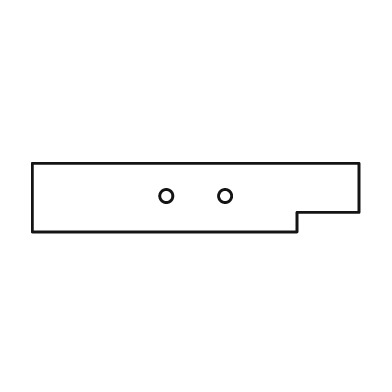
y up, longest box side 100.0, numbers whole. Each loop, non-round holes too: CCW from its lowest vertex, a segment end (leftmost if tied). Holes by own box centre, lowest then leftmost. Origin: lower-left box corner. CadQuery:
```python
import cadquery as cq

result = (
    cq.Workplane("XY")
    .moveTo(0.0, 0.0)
    .lineTo(81.0, 0.0)
    .lineTo(81.0, 6.0)
    .lineTo(100.0, 6.0)
    .lineTo(100.0, 21.0)
    .lineTo(0.0, 21.0)
    .close()
    .moveTo(41.0, 11.0)
    .circle(2.0)
    .moveTo(59.0, 11.0)
    .circle(2.0)
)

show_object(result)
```